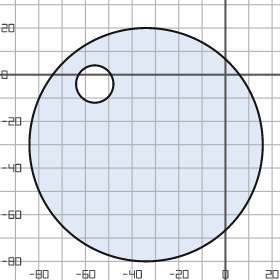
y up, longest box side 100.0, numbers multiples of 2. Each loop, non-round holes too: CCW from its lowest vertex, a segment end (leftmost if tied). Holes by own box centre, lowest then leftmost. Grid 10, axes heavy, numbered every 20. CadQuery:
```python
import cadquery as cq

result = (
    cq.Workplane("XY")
    .moveTo(-34.0, -30.0)
    .circle(50.0)
    .moveTo(-56.0, -4.0)
    .circle(8.0)
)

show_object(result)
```